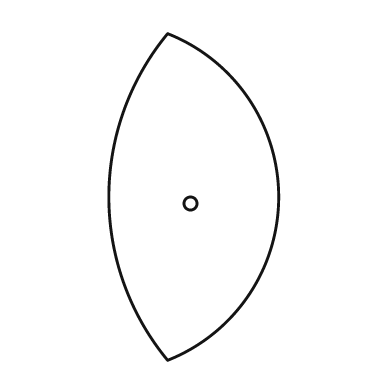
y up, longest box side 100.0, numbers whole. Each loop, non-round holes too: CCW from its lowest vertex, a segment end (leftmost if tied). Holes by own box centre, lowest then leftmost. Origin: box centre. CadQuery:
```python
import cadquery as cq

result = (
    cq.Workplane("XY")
    .moveTo(-8.0, -50.0)
    .threePointArc((26.0, 0.0), (-8.0, 50.0))
    .threePointArc((-26.0, 0.0), (-8.0, -50.0))
    .close()
    .moveTo(-1.0, -2.0)
    .circle(2.0)
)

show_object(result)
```